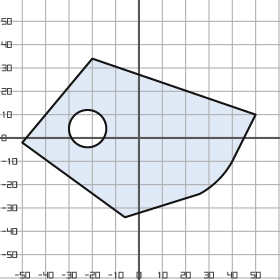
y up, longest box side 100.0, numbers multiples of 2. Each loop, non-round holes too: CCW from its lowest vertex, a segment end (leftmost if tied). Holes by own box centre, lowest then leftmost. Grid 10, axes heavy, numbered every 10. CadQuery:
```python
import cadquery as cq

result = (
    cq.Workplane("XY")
    .moveTo(-6.0, -34.0)
    .lineTo(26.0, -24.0)
    .threePointArc((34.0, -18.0), (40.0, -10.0))
    .lineTo(50.0, 10.0)
    .lineTo(-20.0, 34.0)
    .lineTo(-50.0, -2.0)
    .close()
    .moveTo(-22.0, 4.0)
    .circle(8.0)
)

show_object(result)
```